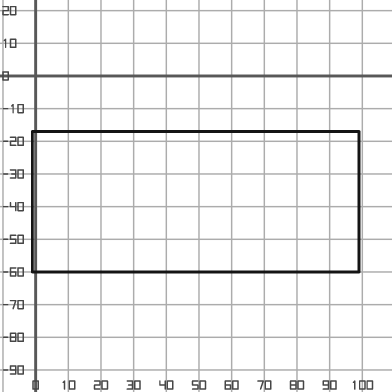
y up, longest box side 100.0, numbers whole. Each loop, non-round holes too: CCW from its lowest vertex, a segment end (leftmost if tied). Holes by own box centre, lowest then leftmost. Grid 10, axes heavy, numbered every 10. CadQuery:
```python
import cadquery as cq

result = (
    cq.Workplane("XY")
    .moveTo(-1.0, -60.0)
    .lineTo(99.0, -60.0)
    .lineTo(99.0, -17.0)
    .lineTo(-1.0, -17.0)
    .close()
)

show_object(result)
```